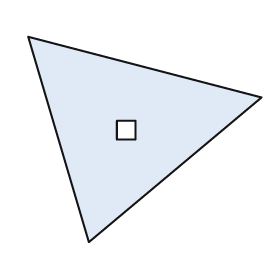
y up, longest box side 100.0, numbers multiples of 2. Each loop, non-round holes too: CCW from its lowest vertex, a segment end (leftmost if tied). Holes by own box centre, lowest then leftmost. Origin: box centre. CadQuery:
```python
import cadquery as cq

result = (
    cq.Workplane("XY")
    .moveTo(-24.0, -44.0)
    .lineTo(50.0, 18.0)
    .lineTo(-50.0, 44.0)
    .close()
    .moveTo(-12.0, 0.0)
    .lineTo(-4.0, 0.0)
    .lineTo(-4.0, 8.0)
    .lineTo(-12.0, 8.0)
    .close()
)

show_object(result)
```